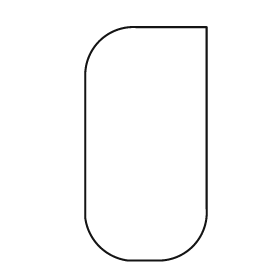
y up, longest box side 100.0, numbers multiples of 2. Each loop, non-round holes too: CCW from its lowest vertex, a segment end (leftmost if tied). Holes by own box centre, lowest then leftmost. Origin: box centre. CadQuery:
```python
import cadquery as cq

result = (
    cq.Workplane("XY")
    .moveTo(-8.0, -50.0)
    .lineTo(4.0, -50.0)
    .threePointArc((20.0, -44.0), (26.0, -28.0))
    .lineTo(26.0, 50.0)
    .lineTo(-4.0, 50.0)
    .threePointArc((-20.0, 44.0), (-26.0, 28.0))
    .lineTo(-26.0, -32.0)
    .threePointArc((-20.0, -44.0), (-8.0, -50.0))
    .close()
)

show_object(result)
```